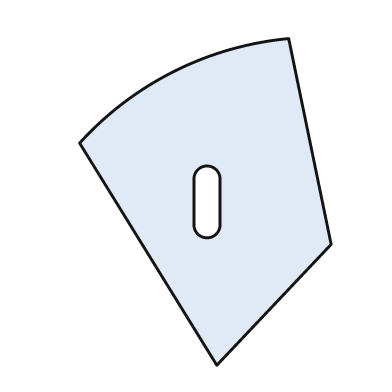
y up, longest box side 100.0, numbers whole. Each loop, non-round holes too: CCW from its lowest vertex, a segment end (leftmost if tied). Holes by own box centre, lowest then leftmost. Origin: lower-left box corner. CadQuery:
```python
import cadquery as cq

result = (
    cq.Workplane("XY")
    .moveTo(42.0, 0.0)
    .lineTo(77.0, 37.0)
    .lineTo(64.0, 100.0)
    .threePointArc((29.0, 90.0), (0.0, 68.0))
    .close()
    .moveTo(35.0, 43.0)
    .threePointArc((39.0, 39.0), (43.0, 43.0))
    .lineTo(43.0, 57.0)
    .threePointArc((39.0, 61.0), (35.0, 57.0))
    .close()
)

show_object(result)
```